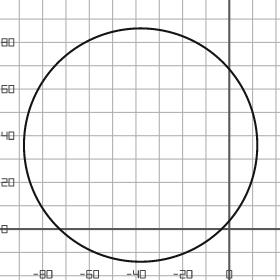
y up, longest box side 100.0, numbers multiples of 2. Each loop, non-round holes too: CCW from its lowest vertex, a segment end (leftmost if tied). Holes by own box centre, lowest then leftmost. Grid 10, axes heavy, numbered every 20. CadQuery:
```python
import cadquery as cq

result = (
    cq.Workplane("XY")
    .moveTo(-38.0, 36.0)
    .circle(50.0)
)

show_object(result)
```